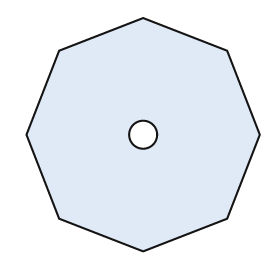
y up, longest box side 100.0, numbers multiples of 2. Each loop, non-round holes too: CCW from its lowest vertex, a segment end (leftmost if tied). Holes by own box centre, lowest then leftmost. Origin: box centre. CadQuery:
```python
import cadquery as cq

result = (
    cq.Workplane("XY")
    .moveTo(0.0, -50.0)
    .lineTo(36.0, -36.0)
    .lineTo(50.0, 0.0)
    .lineTo(36.0, 36.0)
    .lineTo(0.0, 50.0)
    .lineTo(-36.0, 36.0)
    .lineTo(-50.0, 0.0)
    .lineTo(-36.0, -36.0)
    .close()
    .moveTo(0.0, 0.0)
    .circle(6.0)
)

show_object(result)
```